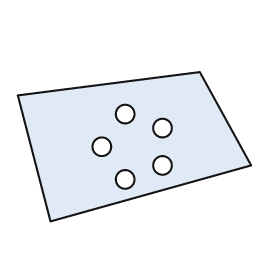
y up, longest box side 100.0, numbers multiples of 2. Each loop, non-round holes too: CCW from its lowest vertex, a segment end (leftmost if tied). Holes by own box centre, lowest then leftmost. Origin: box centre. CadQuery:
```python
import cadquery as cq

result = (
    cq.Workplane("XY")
    .moveTo(-36.0, -32.0)
    .lineTo(50.0, -8.0)
    .lineTo(28.0, 32.0)
    .lineTo(-50.0, 22.0)
    .close()
    .moveTo(-4.0, -14.0)
    .circle(4.0)
    .moveTo(12.0, -8.0)
    .circle(4.0)
    .moveTo(-14.0, 0.0)
    .circle(4.0)
    .moveTo(12.0, 8.0)
    .circle(4.0)
    .moveTo(-4.0, 14.0)
    .circle(4.0)
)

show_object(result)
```